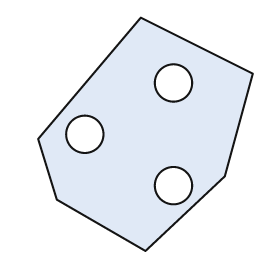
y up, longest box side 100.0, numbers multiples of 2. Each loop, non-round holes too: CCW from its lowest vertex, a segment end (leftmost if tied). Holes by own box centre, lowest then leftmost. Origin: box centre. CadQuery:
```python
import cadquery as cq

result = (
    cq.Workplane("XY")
    .moveTo(0.0, -50.0)
    .lineTo(34.0, -18.0)
    .lineTo(46.0, 26.0)
    .lineTo(-2.0, 50.0)
    .lineTo(-46.0, -2.0)
    .lineTo(-38.0, -28.0)
    .close()
    .moveTo(12.0, -22.0)
    .circle(8.0)
    .moveTo(-26.0, 0.0)
    .circle(8.0)
    .moveTo(12.0, 22.0)
    .circle(8.0)
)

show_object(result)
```